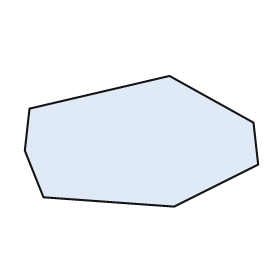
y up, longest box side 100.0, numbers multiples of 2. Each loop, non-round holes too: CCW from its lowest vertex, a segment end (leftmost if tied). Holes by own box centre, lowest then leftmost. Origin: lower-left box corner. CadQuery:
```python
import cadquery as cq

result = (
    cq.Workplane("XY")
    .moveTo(64.0, 0.0)
    .lineTo(100.0, 18.0)
    .lineTo(98.0, 36.0)
    .lineTo(62.0, 56.0)
    .lineTo(2.0, 42.0)
    .lineTo(0.0, 24.0)
    .lineTo(8.0, 4.0)
    .close()
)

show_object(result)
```